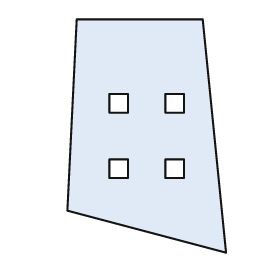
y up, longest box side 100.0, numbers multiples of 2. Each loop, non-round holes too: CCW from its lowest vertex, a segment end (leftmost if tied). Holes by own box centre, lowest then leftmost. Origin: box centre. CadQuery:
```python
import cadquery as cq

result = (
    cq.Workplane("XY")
    .moveTo(34.0, -50.0)
    .lineTo(24.0, 50.0)
    .lineTo(-30.0, 50.0)
    .lineTo(-34.0, -32.0)
    .close()
    .moveTo(-16.0, -18.0)
    .lineTo(-8.0, -18.0)
    .lineTo(-8.0, -10.0)
    .lineTo(-16.0, -10.0)
    .close()
    .moveTo(8.0, -18.0)
    .lineTo(16.0, -18.0)
    .lineTo(16.0, -10.0)
    .lineTo(8.0, -10.0)
    .close()
    .moveTo(-16.0, 10.0)
    .lineTo(-8.0, 10.0)
    .lineTo(-8.0, 18.0)
    .lineTo(-16.0, 18.0)
    .close()
    .moveTo(8.0, 10.0)
    .lineTo(16.0, 10.0)
    .lineTo(16.0, 18.0)
    .lineTo(8.0, 18.0)
    .close()
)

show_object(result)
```